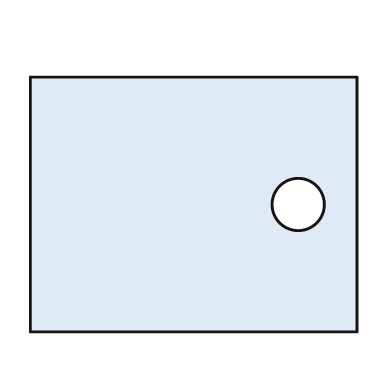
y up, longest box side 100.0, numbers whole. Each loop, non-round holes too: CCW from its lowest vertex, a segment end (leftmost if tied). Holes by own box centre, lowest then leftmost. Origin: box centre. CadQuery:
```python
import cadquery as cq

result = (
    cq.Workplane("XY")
    .moveTo(-50.0, -39.0)
    .lineTo(50.0, -39.0)
    .lineTo(50.0, 39.0)
    .lineTo(-50.0, 39.0)
    .close()
    .moveTo(32.0, 0.0)
    .circle(8.0)
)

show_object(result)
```